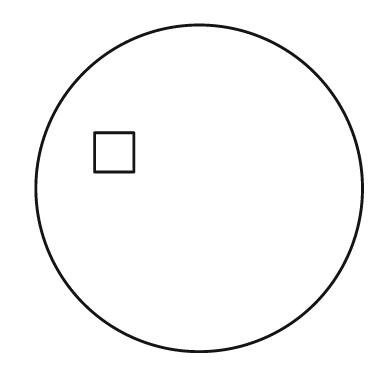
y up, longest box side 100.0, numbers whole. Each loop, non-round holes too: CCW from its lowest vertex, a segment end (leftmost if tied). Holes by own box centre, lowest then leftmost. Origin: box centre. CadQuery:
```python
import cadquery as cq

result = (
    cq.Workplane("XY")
    .moveTo(0.0, 0.0)
    .circle(50.0)
    .moveTo(-32.0, 5.0)
    .lineTo(-20.0, 5.0)
    .lineTo(-20.0, 17.0)
    .lineTo(-32.0, 17.0)
    .close()
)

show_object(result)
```